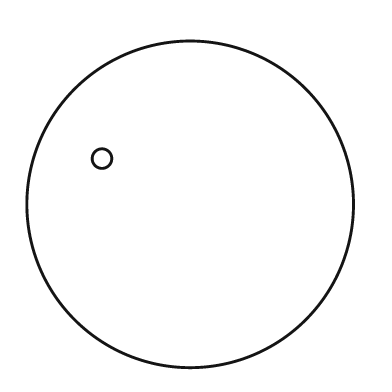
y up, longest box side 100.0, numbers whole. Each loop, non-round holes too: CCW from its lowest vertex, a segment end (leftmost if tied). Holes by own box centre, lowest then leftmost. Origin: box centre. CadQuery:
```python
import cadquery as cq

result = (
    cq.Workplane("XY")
    .moveTo(0.0, 0.0)
    .circle(50.0)
    .moveTo(-27.0, 14.0)
    .circle(3.0)
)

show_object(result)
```